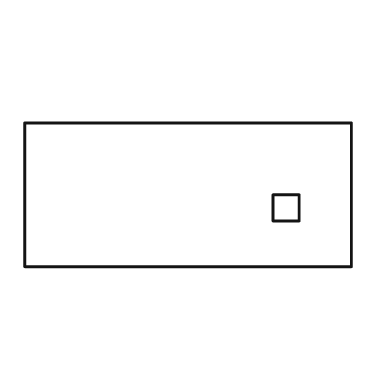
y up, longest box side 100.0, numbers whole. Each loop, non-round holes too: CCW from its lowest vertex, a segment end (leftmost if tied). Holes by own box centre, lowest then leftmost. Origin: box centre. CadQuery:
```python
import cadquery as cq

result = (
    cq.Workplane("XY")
    .moveTo(-50.0, -22.0)
    .lineTo(50.0, -22.0)
    .lineTo(50.0, 22.0)
    .lineTo(-50.0, 22.0)
    .close()
    .moveTo(26.0, -8.0)
    .lineTo(34.0, -8.0)
    .lineTo(34.0, 0.0)
    .lineTo(26.0, 0.0)
    .close()
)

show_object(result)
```